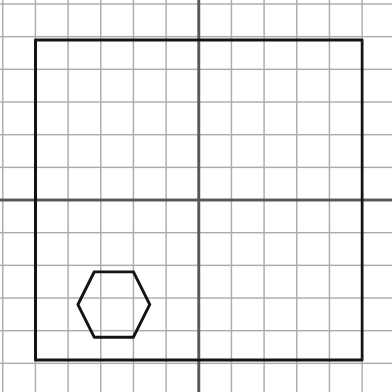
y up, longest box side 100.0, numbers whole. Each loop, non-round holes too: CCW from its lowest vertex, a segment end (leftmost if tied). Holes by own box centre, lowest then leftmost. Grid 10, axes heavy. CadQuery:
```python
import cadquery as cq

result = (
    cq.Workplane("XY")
    .moveTo(-50.0, -49.0)
    .lineTo(50.0, -49.0)
    .lineTo(50.0, 49.0)
    .lineTo(-50.0, 49.0)
    .close()
    .moveTo(-32.0, -42.0)
    .lineTo(-20.0, -42.0)
    .lineTo(-15.0, -32.0)
    .lineTo(-20.0, -22.0)
    .lineTo(-32.0, -22.0)
    .lineTo(-37.0, -32.0)
    .close()
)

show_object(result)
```